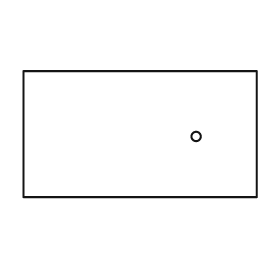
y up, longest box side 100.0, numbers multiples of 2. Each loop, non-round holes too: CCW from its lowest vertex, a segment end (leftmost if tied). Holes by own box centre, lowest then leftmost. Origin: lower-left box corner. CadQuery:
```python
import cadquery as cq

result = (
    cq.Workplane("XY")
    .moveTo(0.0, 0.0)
    .lineTo(100.0, 0.0)
    .lineTo(100.0, 54.0)
    .lineTo(0.0, 54.0)
    .close()
    .moveTo(74.0, 26.0)
    .circle(2.0)
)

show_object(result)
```